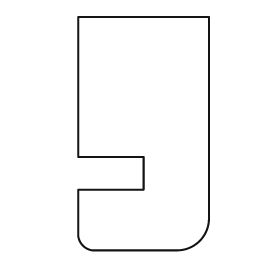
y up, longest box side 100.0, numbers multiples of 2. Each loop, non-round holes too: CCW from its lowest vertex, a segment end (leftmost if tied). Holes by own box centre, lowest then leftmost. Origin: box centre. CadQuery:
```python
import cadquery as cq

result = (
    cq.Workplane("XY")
    .moveTo(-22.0, -50.0)
    .lineTo(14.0, -50.0)
    .threePointArc((24.0, -46.0), (28.0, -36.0))
    .lineTo(28.0, 50.0)
    .lineTo(-28.0, 50.0)
    .lineTo(-28.0, -10.0)
    .lineTo(0.0, -10.0)
    .lineTo(0.0, -24.0)
    .lineTo(-28.0, -24.0)
    .lineTo(-28.0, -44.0)
    .threePointArc((-26.0, -48.0), (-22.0, -50.0))
    .close()
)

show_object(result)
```